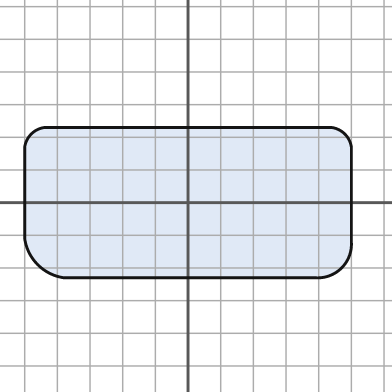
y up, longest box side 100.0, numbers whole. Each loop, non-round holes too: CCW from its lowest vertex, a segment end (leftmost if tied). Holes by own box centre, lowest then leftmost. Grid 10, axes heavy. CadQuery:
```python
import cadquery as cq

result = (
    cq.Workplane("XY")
    .moveTo(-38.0, -23.0)
    .lineTo(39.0, -23.0)
    .threePointArc((47.0, -20.0), (50.0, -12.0))
    .lineTo(50.0, 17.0)
    .threePointArc((48.0, 21.0), (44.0, 23.0))
    .lineTo(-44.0, 23.0)
    .threePointArc((-48.0, 21.0), (-50.0, 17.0))
    .lineTo(-50.0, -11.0)
    .threePointArc((-46.0, -19.0), (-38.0, -23.0))
    .close()
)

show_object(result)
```